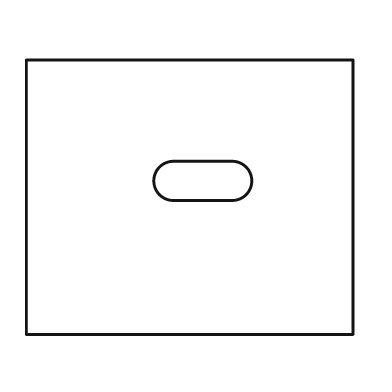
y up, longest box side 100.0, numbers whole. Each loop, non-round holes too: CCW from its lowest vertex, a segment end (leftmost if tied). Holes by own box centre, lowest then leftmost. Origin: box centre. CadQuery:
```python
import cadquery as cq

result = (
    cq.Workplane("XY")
    .moveTo(-50.0, -42.0)
    .lineTo(50.0, -42.0)
    .lineTo(50.0, 42.0)
    .lineTo(-50.0, 42.0)
    .close()
    .moveTo(-5.0, -1.0)
    .lineTo(13.0, -1.0)
    .threePointArc((19.0, 5.0), (13.0, 11.0))
    .lineTo(-5.0, 11.0)
    .threePointArc((-11.0, 5.0), (-5.0, -1.0))
    .close()
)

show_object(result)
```